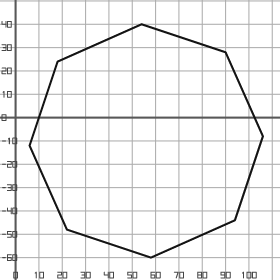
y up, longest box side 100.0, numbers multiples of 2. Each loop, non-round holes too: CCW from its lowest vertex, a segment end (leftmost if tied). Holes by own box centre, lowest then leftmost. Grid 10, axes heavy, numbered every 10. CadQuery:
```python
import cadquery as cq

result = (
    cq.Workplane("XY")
    .moveTo(58.0, -60.0)
    .lineTo(94.0, -44.0)
    .lineTo(106.0, -8.0)
    .lineTo(90.0, 28.0)
    .lineTo(54.0, 40.0)
    .lineTo(18.0, 24.0)
    .lineTo(6.0, -12.0)
    .lineTo(22.0, -48.0)
    .close()
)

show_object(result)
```